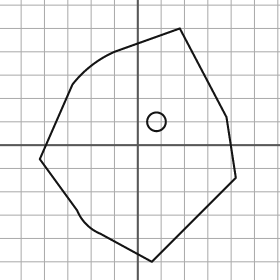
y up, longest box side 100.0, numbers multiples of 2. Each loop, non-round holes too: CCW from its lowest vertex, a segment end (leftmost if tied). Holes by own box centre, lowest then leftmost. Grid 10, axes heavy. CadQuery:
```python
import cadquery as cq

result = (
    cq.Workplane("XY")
    .moveTo(6.0, -50.0)
    .lineTo(42.0, -14.0)
    .lineTo(38.0, 12.0)
    .lineTo(18.0, 50.0)
    .lineTo(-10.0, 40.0)
    .threePointArc((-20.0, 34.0), (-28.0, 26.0))
    .lineTo(-42.0, -6.0)
    .lineTo(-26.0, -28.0)
    .threePointArc((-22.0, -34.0), (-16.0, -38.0))
    .close()
    .moveTo(8.0, 10.0)
    .circle(4.0)
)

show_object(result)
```